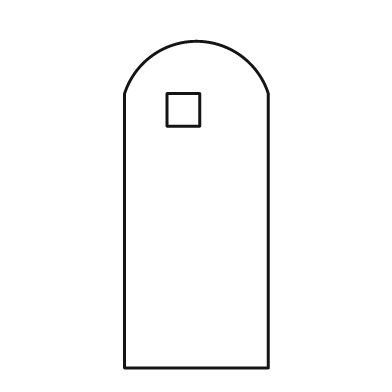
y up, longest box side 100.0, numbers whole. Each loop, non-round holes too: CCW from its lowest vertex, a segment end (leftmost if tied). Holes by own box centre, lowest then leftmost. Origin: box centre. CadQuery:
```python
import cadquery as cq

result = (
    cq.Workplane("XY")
    .moveTo(-22.0, -50.0)
    .lineTo(22.0, -50.0)
    .lineTo(22.0, 34.0)
    .threePointArc((0.0, 50.0), (-22.0, 34.0))
    .close()
    .moveTo(-9.0, 24.0)
    .lineTo(1.0, 24.0)
    .lineTo(1.0, 34.0)
    .lineTo(-9.0, 34.0)
    .close()
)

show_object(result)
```